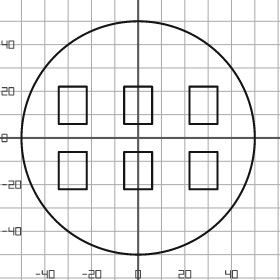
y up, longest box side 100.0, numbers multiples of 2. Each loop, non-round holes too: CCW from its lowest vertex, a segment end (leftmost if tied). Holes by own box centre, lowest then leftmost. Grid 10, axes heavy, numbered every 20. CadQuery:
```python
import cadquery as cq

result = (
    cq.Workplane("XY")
    .moveTo(0.0, 0.0)
    .circle(50.0)
    .moveTo(-34.0, -22.0)
    .lineTo(-22.0, -22.0)
    .lineTo(-22.0, -6.0)
    .lineTo(-34.0, -6.0)
    .close()
    .moveTo(-6.0, -22.0)
    .lineTo(6.0, -22.0)
    .lineTo(6.0, -6.0)
    .lineTo(-6.0, -6.0)
    .close()
    .moveTo(22.0, -22.0)
    .lineTo(34.0, -22.0)
    .lineTo(34.0, -6.0)
    .lineTo(22.0, -6.0)
    .close()
    .moveTo(-34.0, 6.0)
    .lineTo(-22.0, 6.0)
    .lineTo(-22.0, 22.0)
    .lineTo(-34.0, 22.0)
    .close()
    .moveTo(-6.0, 6.0)
    .lineTo(6.0, 6.0)
    .lineTo(6.0, 22.0)
    .lineTo(-6.0, 22.0)
    .close()
    .moveTo(22.0, 6.0)
    .lineTo(34.0, 6.0)
    .lineTo(34.0, 22.0)
    .lineTo(22.0, 22.0)
    .close()
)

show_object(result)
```